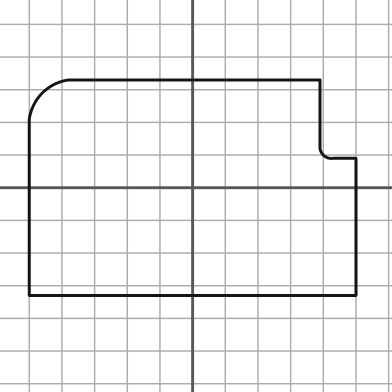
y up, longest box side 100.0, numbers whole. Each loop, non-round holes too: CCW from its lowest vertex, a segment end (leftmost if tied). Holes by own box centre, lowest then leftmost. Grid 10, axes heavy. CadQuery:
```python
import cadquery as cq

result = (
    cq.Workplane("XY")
    .moveTo(-50.0, -33.0)
    .lineTo(50.0, -33.0)
    .lineTo(50.0, 9.0)
    .lineTo(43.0, 9.0)
    .threePointArc((40.0, 10.0), (39.0, 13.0))
    .lineTo(39.0, 33.0)
    .lineTo(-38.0, 33.0)
    .threePointArc((-46.0, 29.0), (-50.0, 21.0))
    .close()
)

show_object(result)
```